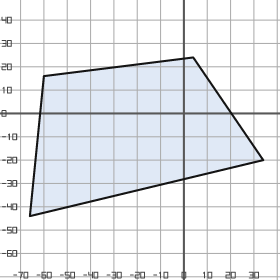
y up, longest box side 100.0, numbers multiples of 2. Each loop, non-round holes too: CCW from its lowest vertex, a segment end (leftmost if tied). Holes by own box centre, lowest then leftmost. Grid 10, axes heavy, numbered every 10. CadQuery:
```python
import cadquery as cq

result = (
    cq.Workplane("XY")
    .moveTo(-66.0, -44.0)
    .lineTo(34.0, -20.0)
    .lineTo(4.0, 24.0)
    .lineTo(-60.0, 16.0)
    .close()
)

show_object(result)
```